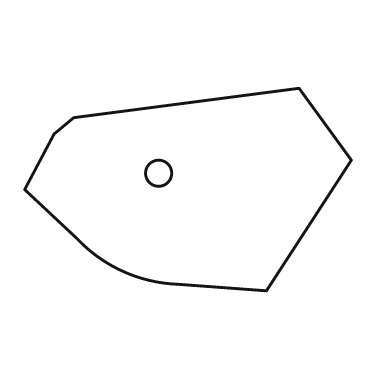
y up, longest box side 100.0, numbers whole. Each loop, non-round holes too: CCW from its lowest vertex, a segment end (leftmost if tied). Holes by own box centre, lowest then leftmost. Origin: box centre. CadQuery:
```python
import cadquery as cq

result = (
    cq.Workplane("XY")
    .moveTo(24.0, -31.0)
    .lineTo(50.0, 9.0)
    .lineTo(34.0, 31.0)
    .lineTo(-35.0, 22.0)
    .lineTo(-41.0, 17.0)
    .lineTo(-50.0, 0.0)
    .lineTo(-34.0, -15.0)
    .threePointArc((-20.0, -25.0), (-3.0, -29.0))
    .close()
    .moveTo(-9.0, 5.0)
    .circle(4.0)
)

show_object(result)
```